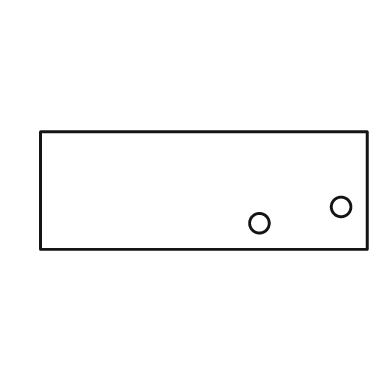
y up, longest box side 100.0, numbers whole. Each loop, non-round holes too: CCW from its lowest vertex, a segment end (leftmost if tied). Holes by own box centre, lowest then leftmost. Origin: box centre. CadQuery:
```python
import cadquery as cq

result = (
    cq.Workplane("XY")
    .moveTo(-50.0, -18.0)
    .lineTo(50.0, -18.0)
    .lineTo(50.0, 18.0)
    .lineTo(-50.0, 18.0)
    .close()
    .moveTo(17.0, -10.0)
    .circle(3.0)
    .moveTo(42.0, -5.0)
    .circle(3.0)
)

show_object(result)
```